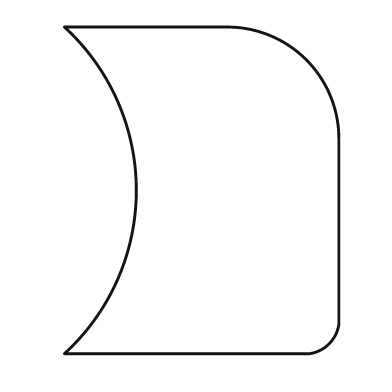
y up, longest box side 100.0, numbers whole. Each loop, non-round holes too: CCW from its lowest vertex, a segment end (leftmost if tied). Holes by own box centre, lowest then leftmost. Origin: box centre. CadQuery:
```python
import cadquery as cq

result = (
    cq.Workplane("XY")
    .moveTo(-42.0, -50.0)
    .lineTo(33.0, -50.0)
    .threePointArc((39.0, -47.0), (42.0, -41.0))
    .lineTo(42.0, 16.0)
    .threePointArc((32.0, 40.0), (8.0, 50.0))
    .lineTo(-42.0, 50.0)
    .threePointArc((-20.0, 0.0), (-42.0, -50.0))
    .close()
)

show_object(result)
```